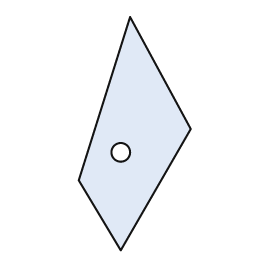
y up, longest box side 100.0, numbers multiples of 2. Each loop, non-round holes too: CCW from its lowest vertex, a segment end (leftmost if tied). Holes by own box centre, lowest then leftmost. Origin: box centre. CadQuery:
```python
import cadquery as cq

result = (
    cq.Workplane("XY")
    .moveTo(-6.0, -50.0)
    .lineTo(24.0, 2.0)
    .lineTo(-2.0, 50.0)
    .lineTo(-24.0, -20.0)
    .close()
    .moveTo(-6.0, -8.0)
    .circle(4.0)
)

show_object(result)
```